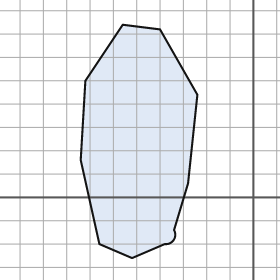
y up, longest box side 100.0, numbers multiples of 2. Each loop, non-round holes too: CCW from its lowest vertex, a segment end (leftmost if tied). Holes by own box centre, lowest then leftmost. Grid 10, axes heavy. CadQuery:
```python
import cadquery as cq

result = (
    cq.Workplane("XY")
    .moveTo(-52.0, -26.0)
    .lineTo(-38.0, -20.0)
    .threePointArc((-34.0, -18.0), (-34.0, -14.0))
    .lineTo(-28.0, 6.0)
    .lineTo(-24.0, 44.0)
    .lineTo(-40.0, 72.0)
    .lineTo(-56.0, 74.0)
    .lineTo(-72.0, 50.0)
    .lineTo(-74.0, 16.0)
    .lineTo(-66.0, -20.0)
    .close()
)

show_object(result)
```